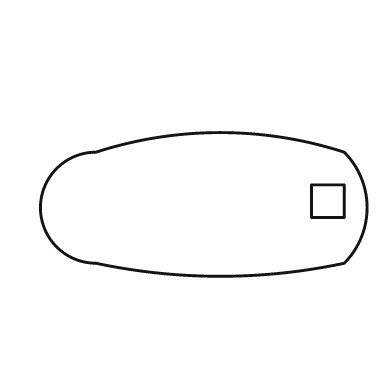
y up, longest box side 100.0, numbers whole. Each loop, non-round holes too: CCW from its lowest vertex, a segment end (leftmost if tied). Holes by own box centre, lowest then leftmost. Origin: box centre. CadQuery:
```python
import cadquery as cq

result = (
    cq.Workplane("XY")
    .moveTo(-33.0, -18.0)
    .threePointArc((5.0, -22.0), (43.0, -18.0))
    .threePointArc((50.0, -1.0), (43.0, 16.0))
    .threePointArc((5.0, 22.0), (-33.0, 16.0))
    .threePointArc((-50.0, -1.0), (-33.0, -18.0))
    .close()
    .moveTo(33.0, -4.0)
    .lineTo(43.0, -4.0)
    .lineTo(43.0, 6.0)
    .lineTo(33.0, 6.0)
    .close()
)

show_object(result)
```